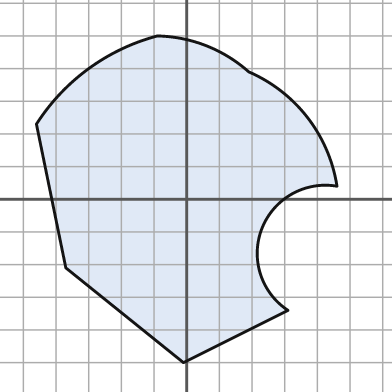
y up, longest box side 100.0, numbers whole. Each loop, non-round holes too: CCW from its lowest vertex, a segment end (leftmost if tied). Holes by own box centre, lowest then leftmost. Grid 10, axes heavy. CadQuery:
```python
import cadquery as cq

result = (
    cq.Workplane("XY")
    .moveTo(-1.0, -50.0)
    .lineTo(31.0, -34.0)
    .threePointArc((23.0, -9.0), (46.0, 4.0))
    .threePointArc((37.0, 25.0), (19.0, 39.0))
    .threePointArc((6.0, 47.0), (-9.0, 50.0))
    .threePointArc((-30.0, 40.0), (-46.0, 23.0))
    .lineTo(-37.0, -21.0)
    .close()
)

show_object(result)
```